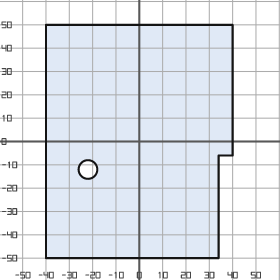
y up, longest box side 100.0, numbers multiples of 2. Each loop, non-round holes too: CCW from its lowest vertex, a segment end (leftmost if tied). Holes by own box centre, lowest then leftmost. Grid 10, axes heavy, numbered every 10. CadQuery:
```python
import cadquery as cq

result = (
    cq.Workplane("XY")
    .moveTo(-40.0, -50.0)
    .lineTo(34.0, -50.0)
    .lineTo(34.0, -6.0)
    .lineTo(40.0, -6.0)
    .lineTo(40.0, 50.0)
    .lineTo(-40.0, 50.0)
    .close()
    .moveTo(-22.0, -12.0)
    .circle(4.0)
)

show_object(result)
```